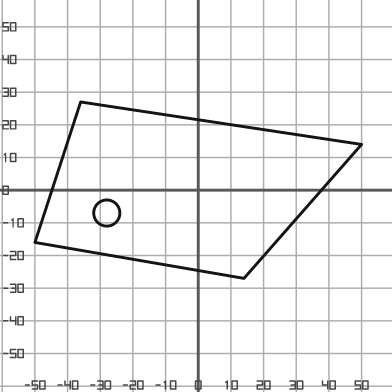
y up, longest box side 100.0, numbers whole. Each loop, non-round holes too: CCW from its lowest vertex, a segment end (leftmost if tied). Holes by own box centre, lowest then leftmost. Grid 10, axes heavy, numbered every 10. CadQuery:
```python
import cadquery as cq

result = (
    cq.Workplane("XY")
    .moveTo(14.0, -27.0)
    .lineTo(50.0, 14.0)
    .lineTo(-36.0, 27.0)
    .lineTo(-50.0, -16.0)
    .close()
    .moveTo(-28.0, -7.0)
    .circle(4.0)
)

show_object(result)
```